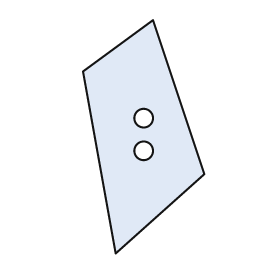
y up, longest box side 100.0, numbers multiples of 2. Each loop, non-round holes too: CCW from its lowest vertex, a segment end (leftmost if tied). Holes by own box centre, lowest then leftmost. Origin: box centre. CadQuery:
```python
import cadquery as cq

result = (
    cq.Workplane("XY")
    .moveTo(-12.0, -50.0)
    .lineTo(26.0, -16.0)
    .lineTo(4.0, 50.0)
    .lineTo(-26.0, 28.0)
    .close()
    .moveTo(0.0, -6.0)
    .circle(4.0)
    .moveTo(0.0, 8.0)
    .circle(4.0)
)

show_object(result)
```